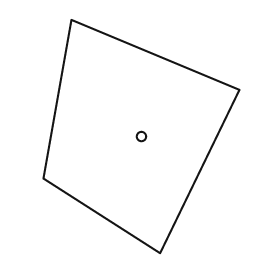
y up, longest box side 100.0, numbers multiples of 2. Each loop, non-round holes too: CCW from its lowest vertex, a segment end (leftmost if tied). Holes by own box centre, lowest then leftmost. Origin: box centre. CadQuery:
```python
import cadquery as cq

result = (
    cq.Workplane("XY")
    .moveTo(8.0, -50.0)
    .lineTo(42.0, 20.0)
    .lineTo(-30.0, 50.0)
    .lineTo(-42.0, -18.0)
    .close()
    .moveTo(0.0, 0.0)
    .circle(2.0)
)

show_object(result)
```